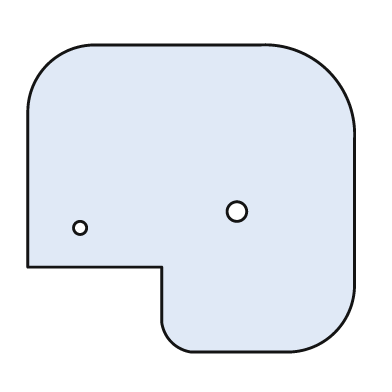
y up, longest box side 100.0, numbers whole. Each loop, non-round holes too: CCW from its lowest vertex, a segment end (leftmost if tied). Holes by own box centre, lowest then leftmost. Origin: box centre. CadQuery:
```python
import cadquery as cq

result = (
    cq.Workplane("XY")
    .moveTo(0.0, -47.0)
    .lineTo(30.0, -47.0)
    .threePointArc((44.0, -41.0), (50.0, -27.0))
    .lineTo(50.0, 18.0)
    .threePointArc((42.0, 39.0), (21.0, 47.0))
    .lineTo(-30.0, 47.0)
    .threePointArc((-44.0, 41.0), (-50.0, 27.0))
    .lineTo(-50.0, -21.0)
    .lineTo(-9.0, -21.0)
    .lineTo(-9.0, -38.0)
    .threePointArc((-6.0, -44.0), (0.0, -47.0))
    .close()
    .moveTo(-34.0, -9.0)
    .circle(2.0)
    .moveTo(14.0, -4.0)
    .circle(3.0)
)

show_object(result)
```